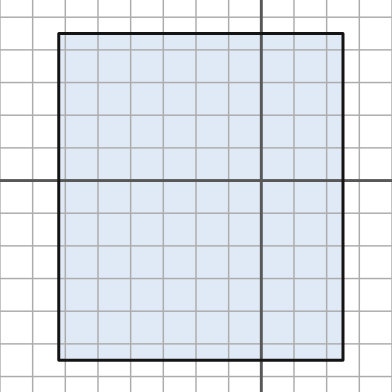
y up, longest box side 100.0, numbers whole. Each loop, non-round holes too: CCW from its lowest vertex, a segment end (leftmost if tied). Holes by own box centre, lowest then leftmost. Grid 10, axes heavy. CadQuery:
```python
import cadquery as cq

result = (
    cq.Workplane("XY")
    .moveTo(-62.0, -55.0)
    .lineTo(25.0, -55.0)
    .lineTo(25.0, 45.0)
    .lineTo(-62.0, 45.0)
    .close()
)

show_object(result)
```